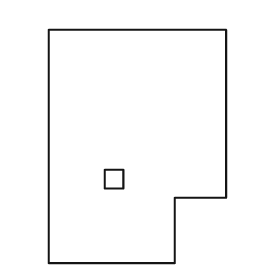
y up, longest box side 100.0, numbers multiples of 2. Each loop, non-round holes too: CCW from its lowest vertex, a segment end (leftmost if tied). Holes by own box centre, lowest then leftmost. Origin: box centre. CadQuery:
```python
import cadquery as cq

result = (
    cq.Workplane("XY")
    .moveTo(-38.0, -50.0)
    .lineTo(16.0, -50.0)
    .lineTo(16.0, -22.0)
    .lineTo(38.0, -22.0)
    .lineTo(38.0, 50.0)
    .lineTo(-38.0, 50.0)
    .close()
    .moveTo(-14.0, -18.0)
    .lineTo(-6.0, -18.0)
    .lineTo(-6.0, -10.0)
    .lineTo(-14.0, -10.0)
    .close()
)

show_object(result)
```